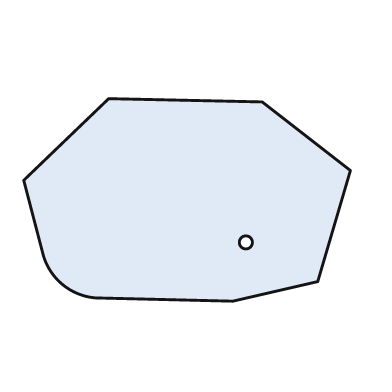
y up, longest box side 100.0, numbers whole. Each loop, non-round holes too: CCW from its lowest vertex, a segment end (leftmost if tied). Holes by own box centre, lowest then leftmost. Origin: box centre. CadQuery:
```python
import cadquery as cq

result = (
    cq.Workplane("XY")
    .moveTo(14.0, -31.0)
    .lineTo(40.0, -25.0)
    .lineTo(50.0, 9.0)
    .lineTo(23.0, 30.0)
    .lineTo(-24.0, 31.0)
    .lineTo(-50.0, 6.0)
    .lineTo(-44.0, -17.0)
    .threePointArc((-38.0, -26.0), (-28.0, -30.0))
    .close()
    .moveTo(18.0, -13.0)
    .circle(2.0)
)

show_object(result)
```